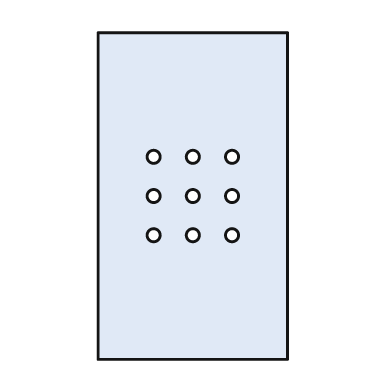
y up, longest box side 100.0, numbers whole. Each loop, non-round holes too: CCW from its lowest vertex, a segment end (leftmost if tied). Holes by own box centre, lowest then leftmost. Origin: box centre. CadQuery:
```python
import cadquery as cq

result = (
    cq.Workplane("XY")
    .moveTo(-29.0, -50.0)
    .lineTo(29.0, -50.0)
    .lineTo(29.0, 50.0)
    .lineTo(-29.0, 50.0)
    .close()
    .moveTo(-12.0, -12.0)
    .circle(2.0)
    .moveTo(0.0, -12.0)
    .circle(2.0)
    .moveTo(12.0, -12.0)
    .circle(2.0)
    .moveTo(-12.0, 0.0)
    .circle(2.0)
    .moveTo(0.0, 0.0)
    .circle(2.0)
    .moveTo(12.0, 0.0)
    .circle(2.0)
    .moveTo(-12.0, 12.0)
    .circle(2.0)
    .moveTo(0.0, 12.0)
    .circle(2.0)
    .moveTo(12.0, 12.0)
    .circle(2.0)
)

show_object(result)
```